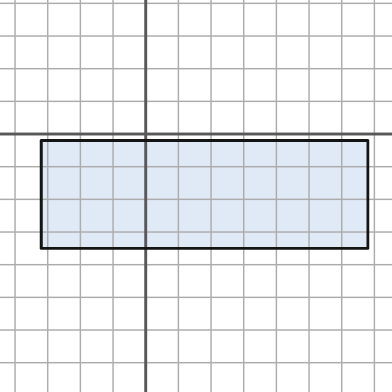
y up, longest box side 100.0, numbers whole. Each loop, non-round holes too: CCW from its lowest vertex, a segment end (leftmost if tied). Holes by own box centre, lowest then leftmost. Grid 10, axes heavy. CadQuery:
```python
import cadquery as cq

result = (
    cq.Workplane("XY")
    .moveTo(-32.0, -35.0)
    .lineTo(68.0, -35.0)
    .lineTo(68.0, -2.0)
    .lineTo(-32.0, -2.0)
    .close()
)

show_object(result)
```